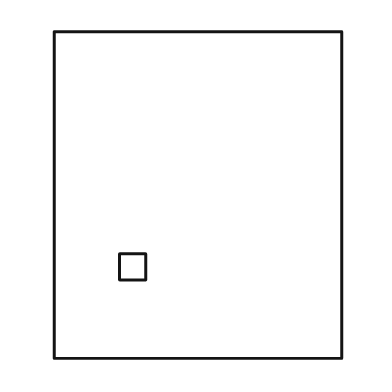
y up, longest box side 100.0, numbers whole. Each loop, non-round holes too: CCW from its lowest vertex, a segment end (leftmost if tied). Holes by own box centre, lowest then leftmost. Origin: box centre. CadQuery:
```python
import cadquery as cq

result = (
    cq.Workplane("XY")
    .moveTo(-44.0, -50.0)
    .lineTo(44.0, -50.0)
    .lineTo(44.0, 50.0)
    .lineTo(-44.0, 50.0)
    .close()
    .moveTo(-24.0, -26.0)
    .lineTo(-16.0, -26.0)
    .lineTo(-16.0, -18.0)
    .lineTo(-24.0, -18.0)
    .close()
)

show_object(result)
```